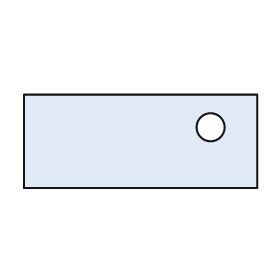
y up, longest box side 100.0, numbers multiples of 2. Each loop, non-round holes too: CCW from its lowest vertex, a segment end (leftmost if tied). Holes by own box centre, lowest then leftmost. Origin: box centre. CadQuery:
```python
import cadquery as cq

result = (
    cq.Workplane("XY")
    .moveTo(-50.0, -20.0)
    .lineTo(50.0, -20.0)
    .lineTo(50.0, 20.0)
    .lineTo(-50.0, 20.0)
    .close()
    .moveTo(30.0, 6.0)
    .circle(6.0)
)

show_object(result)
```